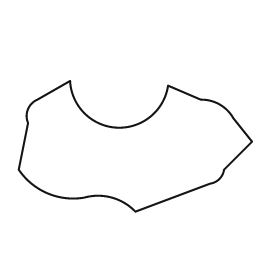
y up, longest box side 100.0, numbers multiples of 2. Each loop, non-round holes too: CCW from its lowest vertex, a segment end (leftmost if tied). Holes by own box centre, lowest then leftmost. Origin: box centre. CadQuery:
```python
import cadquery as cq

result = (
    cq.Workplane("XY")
    .moveTo(0.0, -28.0)
    .lineTo(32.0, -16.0)
    .threePointArc((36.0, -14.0), (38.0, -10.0))
    .lineTo(50.0, 2.0)
    .lineTo(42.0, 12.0)
    .threePointArc((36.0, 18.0), (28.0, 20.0))
    .lineTo(14.0, 26.0)
    .threePointArc((-8.0, 8.0), (-28.0, 28.0))
    .lineTo(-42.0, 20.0)
    .threePointArc((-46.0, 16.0), (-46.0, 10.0))
    .lineTo(-50.0, -10.0)
    .threePointArc((-38.0, -20.0), (-22.0, -22.0))
    .threePointArc((-10.0, -22.0), (0.0, -28.0))
    .close()
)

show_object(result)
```